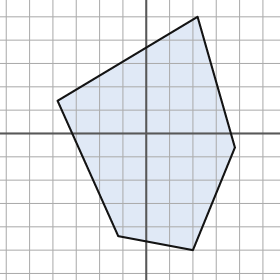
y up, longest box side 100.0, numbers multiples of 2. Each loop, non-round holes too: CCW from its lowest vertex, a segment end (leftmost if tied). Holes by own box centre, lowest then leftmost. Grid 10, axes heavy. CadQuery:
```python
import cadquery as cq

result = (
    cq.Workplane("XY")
    .moveTo(20.0, -50.0)
    .lineTo(38.0, -6.0)
    .lineTo(22.0, 50.0)
    .lineTo(-38.0, 14.0)
    .lineTo(-12.0, -44.0)
    .close()
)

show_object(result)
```